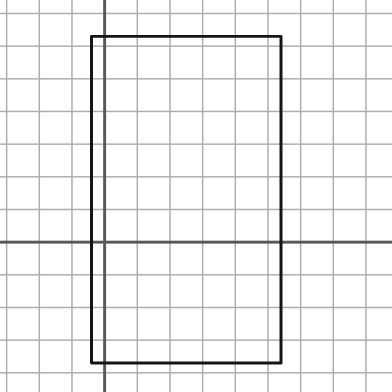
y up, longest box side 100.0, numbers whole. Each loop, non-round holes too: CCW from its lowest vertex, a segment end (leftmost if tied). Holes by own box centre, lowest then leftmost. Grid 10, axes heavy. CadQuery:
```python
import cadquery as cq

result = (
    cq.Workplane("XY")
    .moveTo(-4.0, -37.0)
    .lineTo(54.0, -37.0)
    .lineTo(54.0, 63.0)
    .lineTo(-4.0, 63.0)
    .close()
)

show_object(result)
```